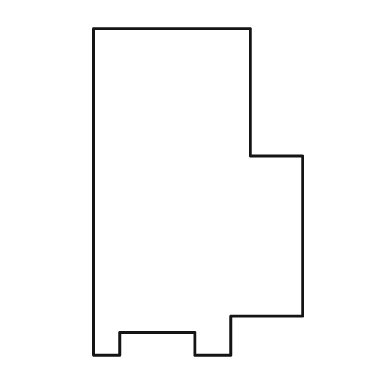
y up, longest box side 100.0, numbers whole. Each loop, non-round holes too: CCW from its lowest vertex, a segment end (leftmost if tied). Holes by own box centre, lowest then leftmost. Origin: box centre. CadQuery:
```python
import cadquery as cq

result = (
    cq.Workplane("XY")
    .moveTo(-32.0, -50.0)
    .lineTo(-24.0, -50.0)
    .lineTo(-24.0, -43.0)
    .lineTo(-1.0, -43.0)
    .lineTo(-1.0, -50.0)
    .lineTo(10.0, -50.0)
    .lineTo(10.0, -38.0)
    .lineTo(32.0, -38.0)
    .lineTo(32.0, 11.0)
    .lineTo(16.0, 11.0)
    .lineTo(16.0, 50.0)
    .lineTo(-32.0, 50.0)
    .close()
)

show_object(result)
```